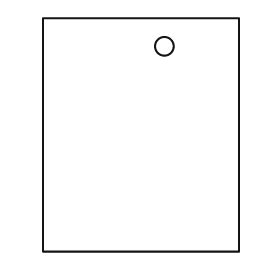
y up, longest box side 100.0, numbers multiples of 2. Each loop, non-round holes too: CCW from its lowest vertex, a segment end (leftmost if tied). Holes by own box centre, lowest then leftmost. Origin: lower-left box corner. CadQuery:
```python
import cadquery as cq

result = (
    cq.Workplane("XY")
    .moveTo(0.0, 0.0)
    .lineTo(84.0, 0.0)
    .lineTo(84.0, 100.0)
    .lineTo(0.0, 100.0)
    .close()
    .moveTo(52.0, 88.0)
    .circle(4.0)
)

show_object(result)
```